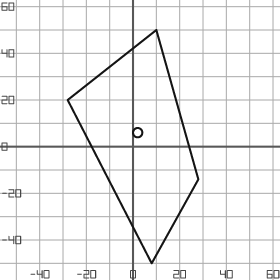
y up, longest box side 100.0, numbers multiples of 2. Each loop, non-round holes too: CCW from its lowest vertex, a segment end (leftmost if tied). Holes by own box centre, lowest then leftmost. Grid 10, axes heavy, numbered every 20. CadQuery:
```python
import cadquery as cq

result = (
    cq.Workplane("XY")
    .moveTo(8.0, -50.0)
    .lineTo(28.0, -14.0)
    .lineTo(10.0, 50.0)
    .lineTo(-28.0, 20.0)
    .close()
    .moveTo(2.0, 6.0)
    .circle(2.0)
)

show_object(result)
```